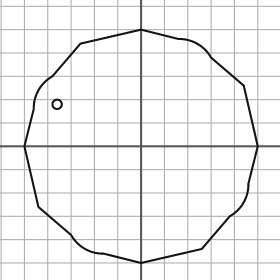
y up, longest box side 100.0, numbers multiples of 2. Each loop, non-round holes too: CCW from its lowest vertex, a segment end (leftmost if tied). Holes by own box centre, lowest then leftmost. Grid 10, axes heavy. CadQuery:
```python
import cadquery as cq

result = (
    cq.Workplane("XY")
    .moveTo(0.0, -50.0)
    .lineTo(26.0, -44.0)
    .lineTo(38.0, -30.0)
    .threePointArc((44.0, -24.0), (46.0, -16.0))
    .lineTo(50.0, 0.0)
    .lineTo(44.0, 26.0)
    .lineTo(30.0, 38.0)
    .threePointArc((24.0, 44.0), (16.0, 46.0))
    .lineTo(0.0, 50.0)
    .lineTo(-26.0, 44.0)
    .lineTo(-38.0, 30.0)
    .threePointArc((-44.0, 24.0), (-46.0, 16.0))
    .lineTo(-50.0, 0.0)
    .lineTo(-44.0, -26.0)
    .lineTo(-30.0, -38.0)
    .threePointArc((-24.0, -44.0), (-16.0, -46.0))
    .close()
    .moveTo(-36.0, 18.0)
    .circle(2.0)
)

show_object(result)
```